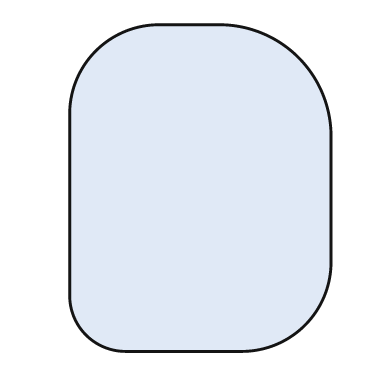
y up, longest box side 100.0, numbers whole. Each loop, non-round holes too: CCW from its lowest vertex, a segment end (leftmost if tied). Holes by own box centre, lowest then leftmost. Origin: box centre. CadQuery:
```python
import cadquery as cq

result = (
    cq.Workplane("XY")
    .moveTo(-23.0, -50.0)
    .lineTo(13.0, -50.0)
    .threePointArc((32.0, -42.0), (40.0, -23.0))
    .lineTo(40.0, 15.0)
    .threePointArc((30.0, 40.0), (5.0, 50.0))
    .lineTo(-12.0, 50.0)
    .threePointArc((-32.0, 42.0), (-40.0, 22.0))
    .lineTo(-40.0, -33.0)
    .threePointArc((-35.0, -45.0), (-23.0, -50.0))
    .close()
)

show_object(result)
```